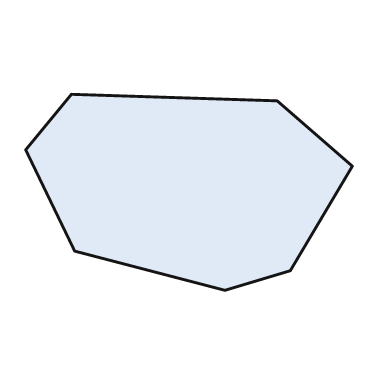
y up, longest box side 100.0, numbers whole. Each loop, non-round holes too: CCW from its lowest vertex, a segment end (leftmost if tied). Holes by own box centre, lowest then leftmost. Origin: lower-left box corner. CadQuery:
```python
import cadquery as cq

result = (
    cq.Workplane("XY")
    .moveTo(61.0, 0.0)
    .lineTo(81.0, 6.0)
    .lineTo(100.0, 38.0)
    .lineTo(77.0, 58.0)
    .lineTo(14.0, 60.0)
    .lineTo(0.0, 43.0)
    .lineTo(15.0, 12.0)
    .close()
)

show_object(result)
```